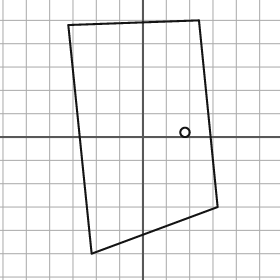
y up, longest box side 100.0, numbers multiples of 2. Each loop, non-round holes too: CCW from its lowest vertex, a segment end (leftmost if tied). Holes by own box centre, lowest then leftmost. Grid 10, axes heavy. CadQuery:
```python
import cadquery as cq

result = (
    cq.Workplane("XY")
    .moveTo(-22.0, -50.0)
    .lineTo(32.0, -30.0)
    .lineTo(24.0, 50.0)
    .lineTo(-32.0, 48.0)
    .close()
    .moveTo(18.0, 2.0)
    .circle(2.0)
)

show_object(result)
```